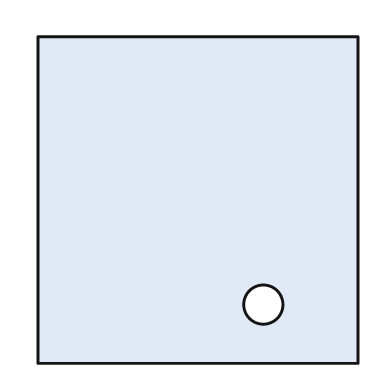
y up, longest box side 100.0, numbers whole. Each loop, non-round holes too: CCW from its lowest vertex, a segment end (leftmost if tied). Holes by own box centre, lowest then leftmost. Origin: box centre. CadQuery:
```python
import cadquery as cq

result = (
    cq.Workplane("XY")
    .moveTo(-49.0, -50.0)
    .lineTo(49.0, -50.0)
    .lineTo(49.0, 50.0)
    .lineTo(-49.0, 50.0)
    .close()
    .moveTo(20.0, -32.0)
    .circle(6.0)
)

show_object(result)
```